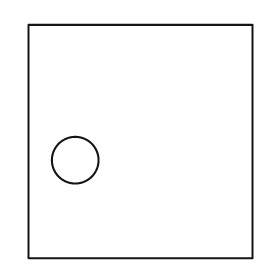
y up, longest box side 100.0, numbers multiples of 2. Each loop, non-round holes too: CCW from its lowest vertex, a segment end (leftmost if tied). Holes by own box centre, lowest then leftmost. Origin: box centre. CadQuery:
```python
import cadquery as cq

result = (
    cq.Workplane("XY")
    .moveTo(-48.0, -50.0)
    .lineTo(48.0, -50.0)
    .lineTo(48.0, 50.0)
    .lineTo(-48.0, 50.0)
    .close()
    .moveTo(-28.0, -8.0)
    .circle(10.0)
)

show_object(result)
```